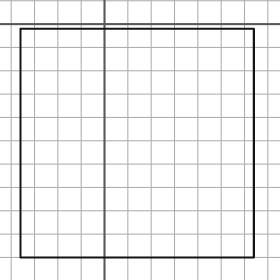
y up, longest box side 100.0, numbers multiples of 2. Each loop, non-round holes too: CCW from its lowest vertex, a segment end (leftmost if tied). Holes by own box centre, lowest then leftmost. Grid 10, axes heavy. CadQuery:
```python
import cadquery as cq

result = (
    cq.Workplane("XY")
    .moveTo(-36.0, -100.0)
    .lineTo(64.0, -100.0)
    .lineTo(64.0, -2.0)
    .lineTo(-36.0, -2.0)
    .close()
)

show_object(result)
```